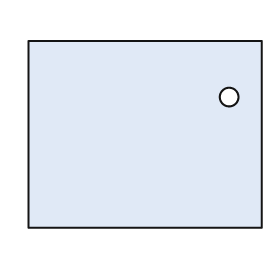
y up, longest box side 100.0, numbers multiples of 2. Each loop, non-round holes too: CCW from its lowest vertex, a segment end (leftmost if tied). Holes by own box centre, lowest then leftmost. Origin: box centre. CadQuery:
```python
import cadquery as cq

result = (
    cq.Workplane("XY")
    .moveTo(-50.0, -40.0)
    .lineTo(50.0, -40.0)
    .lineTo(50.0, 40.0)
    .lineTo(-50.0, 40.0)
    .close()
    .moveTo(36.0, 16.0)
    .circle(4.0)
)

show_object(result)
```